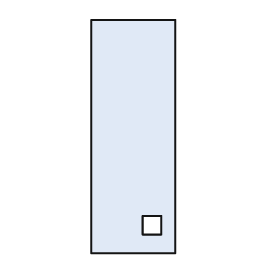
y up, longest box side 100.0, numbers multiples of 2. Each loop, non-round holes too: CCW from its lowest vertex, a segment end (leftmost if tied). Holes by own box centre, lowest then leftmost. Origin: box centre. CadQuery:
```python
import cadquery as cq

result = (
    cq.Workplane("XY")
    .moveTo(-18.0, -50.0)
    .lineTo(18.0, -50.0)
    .lineTo(18.0, 50.0)
    .lineTo(-18.0, 50.0)
    .close()
    .moveTo(4.0, -42.0)
    .lineTo(12.0, -42.0)
    .lineTo(12.0, -34.0)
    .lineTo(4.0, -34.0)
    .close()
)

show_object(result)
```